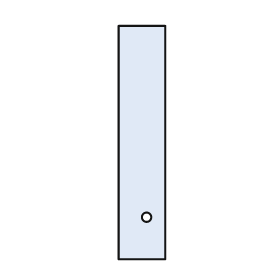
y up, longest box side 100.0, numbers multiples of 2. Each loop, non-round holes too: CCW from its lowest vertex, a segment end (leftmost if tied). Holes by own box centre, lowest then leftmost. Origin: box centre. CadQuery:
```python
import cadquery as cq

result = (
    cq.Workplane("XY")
    .moveTo(-10.0, -50.0)
    .lineTo(10.0, -50.0)
    .lineTo(10.0, 50.0)
    .lineTo(-10.0, 50.0)
    .close()
    .moveTo(2.0, -32.0)
    .circle(2.0)
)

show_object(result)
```